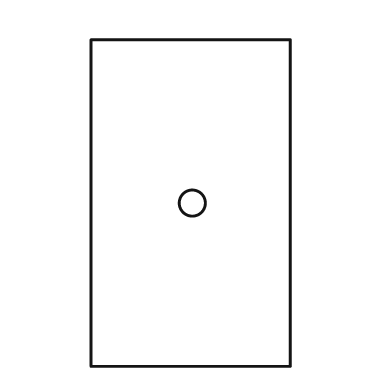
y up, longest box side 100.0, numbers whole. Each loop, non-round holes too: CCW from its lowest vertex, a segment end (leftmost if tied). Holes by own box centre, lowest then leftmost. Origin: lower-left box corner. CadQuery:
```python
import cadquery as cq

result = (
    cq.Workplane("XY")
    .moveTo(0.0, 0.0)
    .lineTo(61.0, 0.0)
    .lineTo(61.0, 100.0)
    .lineTo(0.0, 100.0)
    .close()
    .moveTo(31.0, 50.0)
    .circle(4.0)
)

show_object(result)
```